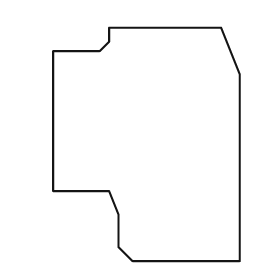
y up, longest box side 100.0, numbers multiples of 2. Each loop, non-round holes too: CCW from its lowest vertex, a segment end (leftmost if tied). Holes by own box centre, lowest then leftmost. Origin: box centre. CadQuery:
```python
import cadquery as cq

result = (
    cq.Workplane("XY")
    .moveTo(-6.0, -50.0)
    .lineTo(40.0, -50.0)
    .lineTo(40.0, 30.0)
    .lineTo(32.0, 50.0)
    .lineTo(-16.0, 50.0)
    .lineTo(-16.0, 44.0)
    .lineTo(-20.0, 40.0)
    .lineTo(-40.0, 40.0)
    .lineTo(-40.0, -20.0)
    .lineTo(-16.0, -20.0)
    .lineTo(-12.0, -30.0)
    .lineTo(-12.0, -44.0)
    .close()
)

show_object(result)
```